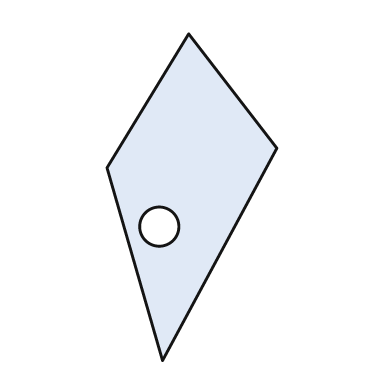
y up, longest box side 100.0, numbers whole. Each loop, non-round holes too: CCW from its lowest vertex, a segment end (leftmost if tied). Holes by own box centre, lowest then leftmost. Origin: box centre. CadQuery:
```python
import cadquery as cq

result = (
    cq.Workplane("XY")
    .moveTo(-9.0, -50.0)
    .lineTo(26.0, 15.0)
    .lineTo(-1.0, 50.0)
    .lineTo(-26.0, 9.0)
    .close()
    .moveTo(-10.0, -9.0)
    .circle(6.0)
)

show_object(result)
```